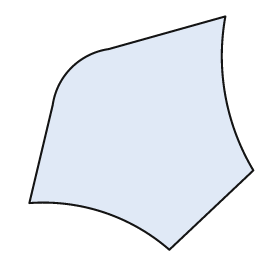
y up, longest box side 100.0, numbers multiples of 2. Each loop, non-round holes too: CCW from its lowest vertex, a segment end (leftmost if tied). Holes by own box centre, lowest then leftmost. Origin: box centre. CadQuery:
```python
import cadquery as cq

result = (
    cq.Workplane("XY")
    .moveTo(12.0, -50.0)
    .lineTo(48.0, -16.0)
    .threePointArc((36.0, 16.0), (36.0, 50.0))
    .lineTo(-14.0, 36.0)
    .threePointArc((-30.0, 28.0), (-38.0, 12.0))
    .lineTo(-48.0, -30.0)
    .threePointArc((-16.0, -34.0), (12.0, -50.0))
    .close()
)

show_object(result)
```